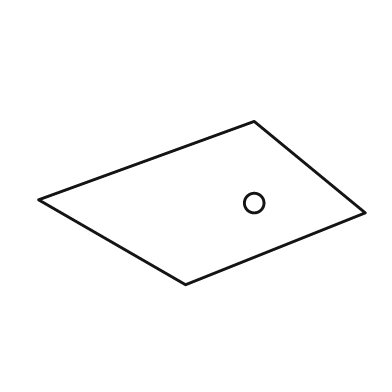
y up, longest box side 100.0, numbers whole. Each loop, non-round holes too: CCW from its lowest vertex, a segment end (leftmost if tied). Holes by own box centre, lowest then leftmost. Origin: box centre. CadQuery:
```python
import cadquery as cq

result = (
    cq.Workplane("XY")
    .moveTo(-5.0, -25.0)
    .lineTo(50.0, -3.0)
    .lineTo(16.0, 25.0)
    .lineTo(-50.0, 1.0)
    .close()
    .moveTo(16.0, 0.0)
    .circle(3.0)
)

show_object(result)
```